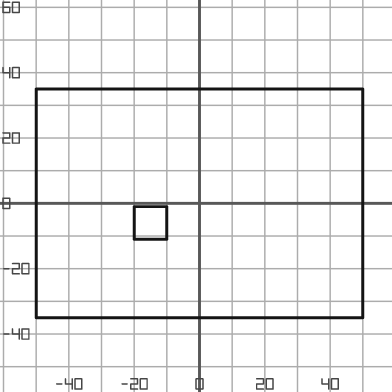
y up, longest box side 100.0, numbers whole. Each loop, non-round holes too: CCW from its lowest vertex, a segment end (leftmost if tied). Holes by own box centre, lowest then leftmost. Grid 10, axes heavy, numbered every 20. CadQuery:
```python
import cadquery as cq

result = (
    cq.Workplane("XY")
    .moveTo(-50.0, -35.0)
    .lineTo(50.0, -35.0)
    .lineTo(50.0, 35.0)
    .lineTo(-50.0, 35.0)
    .close()
    .moveTo(-20.0, -11.0)
    .lineTo(-10.0, -11.0)
    .lineTo(-10.0, -1.0)
    .lineTo(-20.0, -1.0)
    .close()
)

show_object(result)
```